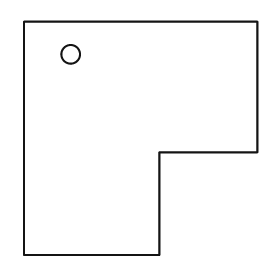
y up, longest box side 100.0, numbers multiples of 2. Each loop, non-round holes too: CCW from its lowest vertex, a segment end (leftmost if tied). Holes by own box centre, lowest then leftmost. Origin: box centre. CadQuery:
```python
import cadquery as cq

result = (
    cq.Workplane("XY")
    .moveTo(-50.0, -50.0)
    .lineTo(8.0, -50.0)
    .lineTo(8.0, -6.0)
    .lineTo(50.0, -6.0)
    .lineTo(50.0, 50.0)
    .lineTo(-50.0, 50.0)
    .close()
    .moveTo(-30.0, 36.0)
    .circle(4.0)
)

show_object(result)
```